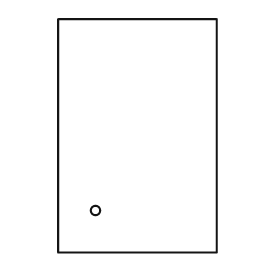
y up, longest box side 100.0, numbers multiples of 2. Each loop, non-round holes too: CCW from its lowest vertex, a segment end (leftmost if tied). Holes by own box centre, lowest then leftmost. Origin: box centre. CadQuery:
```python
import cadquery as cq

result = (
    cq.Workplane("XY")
    .moveTo(-34.0, -50.0)
    .lineTo(34.0, -50.0)
    .lineTo(34.0, 50.0)
    .lineTo(-34.0, 50.0)
    .close()
    .moveTo(-18.0, -32.0)
    .circle(2.0)
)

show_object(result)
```